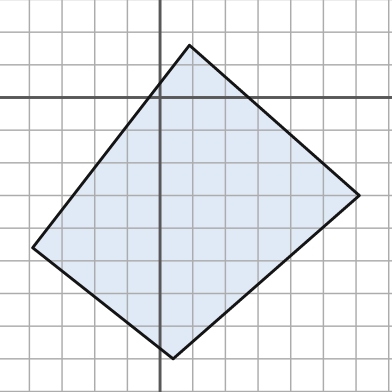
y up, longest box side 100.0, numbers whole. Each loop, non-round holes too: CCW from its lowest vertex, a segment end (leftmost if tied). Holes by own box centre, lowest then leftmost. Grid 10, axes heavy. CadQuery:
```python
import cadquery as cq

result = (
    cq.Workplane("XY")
    .moveTo(4.0, -80.0)
    .lineTo(61.0, -30.0)
    .lineTo(9.0, 16.0)
    .lineTo(-39.0, -46.0)
    .close()
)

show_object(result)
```